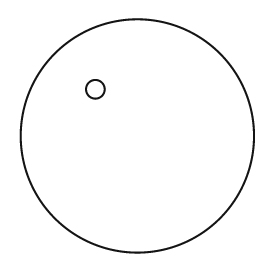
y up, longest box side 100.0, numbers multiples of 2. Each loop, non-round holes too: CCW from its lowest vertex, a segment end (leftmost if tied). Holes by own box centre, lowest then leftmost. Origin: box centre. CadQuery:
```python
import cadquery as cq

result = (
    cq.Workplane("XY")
    .moveTo(0.0, 0.0)
    .circle(50.0)
    .moveTo(-18.0, 20.0)
    .circle(4.0)
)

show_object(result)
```